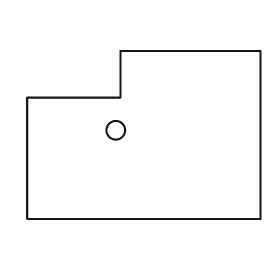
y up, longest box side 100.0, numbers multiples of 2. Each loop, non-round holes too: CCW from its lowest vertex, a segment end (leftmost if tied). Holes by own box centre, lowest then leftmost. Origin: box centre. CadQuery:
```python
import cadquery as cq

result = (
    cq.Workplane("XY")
    .moveTo(-50.0, -36.0)
    .lineTo(50.0, -36.0)
    .lineTo(50.0, 36.0)
    .lineTo(-10.0, 36.0)
    .lineTo(-10.0, 16.0)
    .lineTo(-50.0, 16.0)
    .close()
    .moveTo(-12.0, 2.0)
    .circle(4.0)
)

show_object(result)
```